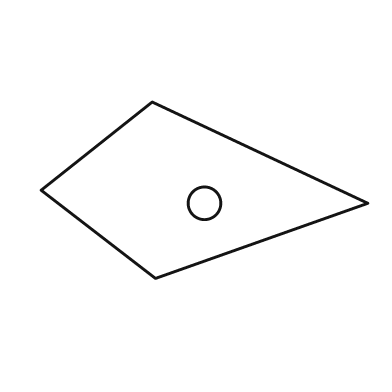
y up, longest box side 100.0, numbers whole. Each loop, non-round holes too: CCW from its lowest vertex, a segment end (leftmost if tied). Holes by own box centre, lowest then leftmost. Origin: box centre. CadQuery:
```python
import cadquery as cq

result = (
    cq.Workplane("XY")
    .moveTo(-15.0, -27.0)
    .lineTo(50.0, -4.0)
    .lineTo(-16.0, 27.0)
    .lineTo(-50.0, 0.0)
    .close()
    .moveTo(0.0, -4.0)
    .circle(5.0)
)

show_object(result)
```